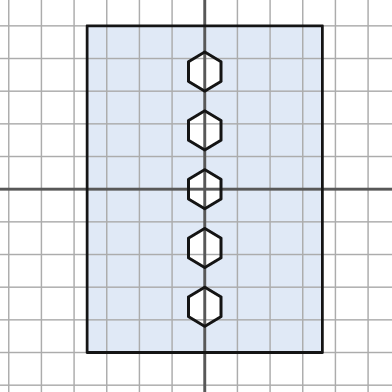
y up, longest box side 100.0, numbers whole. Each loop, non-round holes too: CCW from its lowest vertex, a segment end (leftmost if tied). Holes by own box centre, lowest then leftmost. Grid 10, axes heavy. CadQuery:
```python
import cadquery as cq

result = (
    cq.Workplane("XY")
    .moveTo(-36.0, -50.0)
    .lineTo(36.0, -50.0)
    .lineTo(36.0, 50.0)
    .lineTo(-36.0, 50.0)
    .close()
    .moveTo(0.0, -42.0)
    .lineTo(5.0, -39.0)
    .lineTo(5.0, -33.0)
    .lineTo(0.0, -30.0)
    .lineTo(-5.0, -33.0)
    .lineTo(-5.0, -39.0)
    .close()
    .moveTo(0.0, -24.0)
    .lineTo(5.0, -21.0)
    .lineTo(5.0, -15.0)
    .lineTo(0.0, -12.0)
    .lineTo(-5.0, -15.0)
    .lineTo(-5.0, -21.0)
    .close()
    .moveTo(0.0, -6.0)
    .lineTo(5.0, -3.0)
    .lineTo(5.0, 3.0)
    .lineTo(0.0, 6.0)
    .lineTo(-5.0, 3.0)
    .lineTo(-5.0, -3.0)
    .close()
    .moveTo(0.0, 12.0)
    .lineTo(5.0, 15.0)
    .lineTo(5.0, 21.0)
    .lineTo(0.0, 24.0)
    .lineTo(-5.0, 21.0)
    .lineTo(-5.0, 15.0)
    .close()
    .moveTo(0.0, 30.0)
    .lineTo(5.0, 33.0)
    .lineTo(5.0, 39.0)
    .lineTo(0.0, 42.0)
    .lineTo(-5.0, 39.0)
    .lineTo(-5.0, 33.0)
    .close()
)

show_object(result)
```